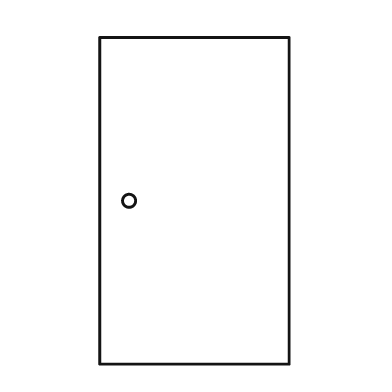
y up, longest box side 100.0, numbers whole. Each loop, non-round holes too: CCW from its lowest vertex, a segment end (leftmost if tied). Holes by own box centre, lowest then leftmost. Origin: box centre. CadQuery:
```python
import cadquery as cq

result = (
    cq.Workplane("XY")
    .moveTo(-29.0, -50.0)
    .lineTo(29.0, -50.0)
    .lineTo(29.0, 50.0)
    .lineTo(-29.0, 50.0)
    .close()
    .moveTo(-20.0, 0.0)
    .circle(2.0)
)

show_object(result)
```